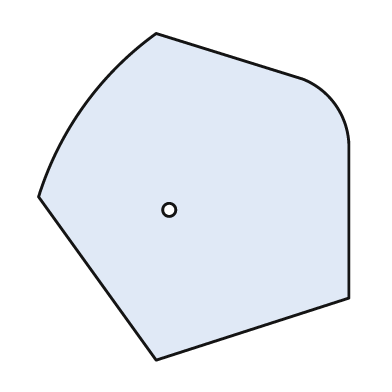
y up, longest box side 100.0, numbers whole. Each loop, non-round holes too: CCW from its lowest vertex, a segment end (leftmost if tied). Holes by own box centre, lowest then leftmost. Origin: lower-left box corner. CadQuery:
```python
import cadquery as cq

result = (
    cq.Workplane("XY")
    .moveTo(36.0, 0.0)
    .lineTo(95.0, 19.0)
    .lineTo(95.0, 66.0)
    .threePointArc((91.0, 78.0), (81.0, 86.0))
    .lineTo(36.0, 100.0)
    .threePointArc((14.0, 78.0), (0.0, 50.0))
    .close()
    .moveTo(40.0, 46.0)
    .circle(2.0)
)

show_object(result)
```